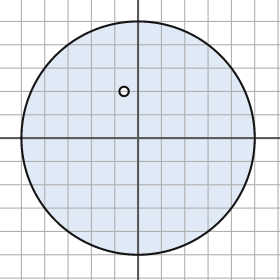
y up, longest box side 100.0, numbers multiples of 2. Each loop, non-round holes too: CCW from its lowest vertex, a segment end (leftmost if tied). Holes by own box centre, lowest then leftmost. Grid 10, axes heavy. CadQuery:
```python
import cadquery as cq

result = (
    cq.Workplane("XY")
    .moveTo(0.0, 0.0)
    .circle(50.0)
    .moveTo(-6.0, 20.0)
    .circle(2.0)
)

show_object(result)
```